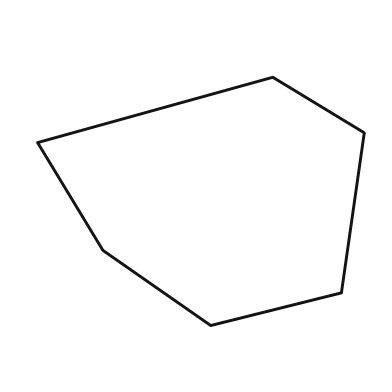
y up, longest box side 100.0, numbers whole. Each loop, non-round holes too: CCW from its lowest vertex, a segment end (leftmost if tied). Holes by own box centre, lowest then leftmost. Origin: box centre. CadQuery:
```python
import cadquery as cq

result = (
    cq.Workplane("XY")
    .moveTo(3.0, -38.0)
    .lineTo(43.0, -28.0)
    .lineTo(50.0, 21.0)
    .lineTo(22.0, 38.0)
    .lineTo(-50.0, 18.0)
    .lineTo(-30.0, -15.0)
    .close()
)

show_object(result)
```